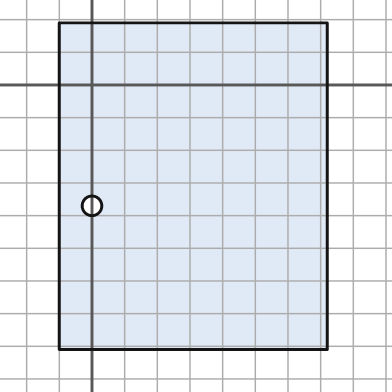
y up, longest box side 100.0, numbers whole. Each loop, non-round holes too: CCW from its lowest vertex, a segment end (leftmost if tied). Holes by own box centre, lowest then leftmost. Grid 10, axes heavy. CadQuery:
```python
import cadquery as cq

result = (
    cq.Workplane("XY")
    .moveTo(-10.0, -81.0)
    .lineTo(72.0, -81.0)
    .lineTo(72.0, 19.0)
    .lineTo(-10.0, 19.0)
    .close()
    .moveTo(0.0, -37.0)
    .circle(3.0)
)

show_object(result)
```